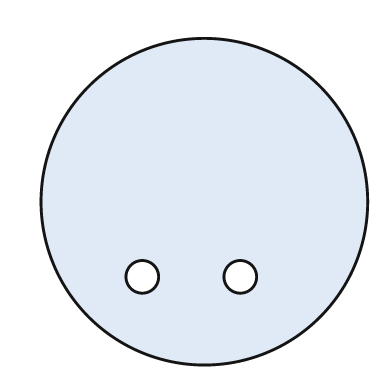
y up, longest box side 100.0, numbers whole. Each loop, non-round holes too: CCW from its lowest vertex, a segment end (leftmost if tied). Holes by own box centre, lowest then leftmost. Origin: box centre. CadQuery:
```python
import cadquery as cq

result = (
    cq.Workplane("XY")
    .moveTo(0.0, 0.0)
    .circle(50.0)
    .moveTo(-19.0, -23.0)
    .circle(5.0)
    .moveTo(11.0, -23.0)
    .circle(5.0)
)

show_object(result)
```